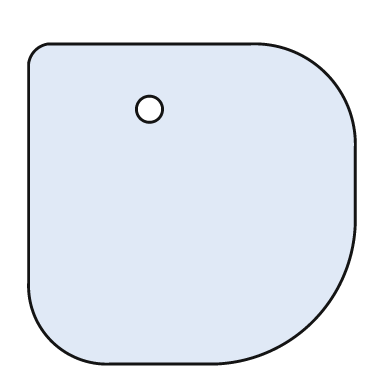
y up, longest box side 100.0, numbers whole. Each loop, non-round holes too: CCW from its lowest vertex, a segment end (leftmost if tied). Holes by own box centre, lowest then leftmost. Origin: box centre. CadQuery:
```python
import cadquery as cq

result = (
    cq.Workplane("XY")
    .moveTo(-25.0, -49.0)
    .lineTo(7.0, -49.0)
    .threePointArc((37.0, -36.0), (50.0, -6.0))
    .lineTo(50.0, 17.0)
    .threePointArc((41.0, 40.0), (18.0, 49.0))
    .lineTo(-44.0, 49.0)
    .threePointArc((-48.0, 47.0), (-50.0, 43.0))
    .lineTo(-50.0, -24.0)
    .threePointArc((-43.0, -42.0), (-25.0, -49.0))
    .close()
    .moveTo(-13.0, 29.0)
    .circle(4.0)
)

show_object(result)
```